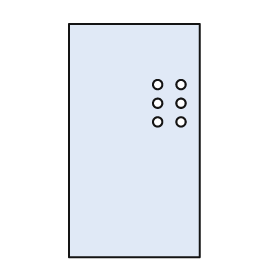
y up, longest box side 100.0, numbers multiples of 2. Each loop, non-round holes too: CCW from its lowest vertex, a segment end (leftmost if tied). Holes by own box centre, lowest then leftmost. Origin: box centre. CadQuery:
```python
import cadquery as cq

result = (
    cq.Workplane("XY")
    .moveTo(-28.0, -50.0)
    .lineTo(28.0, -50.0)
    .lineTo(28.0, 50.0)
    .lineTo(-28.0, 50.0)
    .close()
    .moveTo(10.0, 8.0)
    .circle(2.0)
    .moveTo(20.0, 8.0)
    .circle(2.0)
    .moveTo(10.0, 16.0)
    .circle(2.0)
    .moveTo(20.0, 16.0)
    .circle(2.0)
    .moveTo(10.0, 24.0)
    .circle(2.0)
    .moveTo(20.0, 24.0)
    .circle(2.0)
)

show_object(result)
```